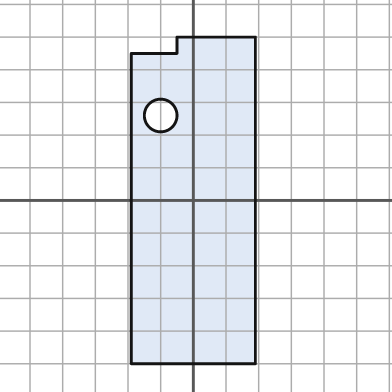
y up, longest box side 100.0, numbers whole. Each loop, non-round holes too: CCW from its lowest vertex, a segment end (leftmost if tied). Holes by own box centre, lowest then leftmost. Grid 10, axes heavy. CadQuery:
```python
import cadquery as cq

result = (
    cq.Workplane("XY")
    .moveTo(-19.0, -50.0)
    .lineTo(19.0, -50.0)
    .lineTo(19.0, 50.0)
    .lineTo(-5.0, 50.0)
    .lineTo(-5.0, 45.0)
    .lineTo(-19.0, 45.0)
    .close()
    .moveTo(-10.0, 26.0)
    .circle(5.0)
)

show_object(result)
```